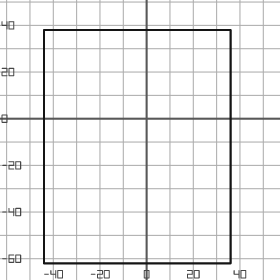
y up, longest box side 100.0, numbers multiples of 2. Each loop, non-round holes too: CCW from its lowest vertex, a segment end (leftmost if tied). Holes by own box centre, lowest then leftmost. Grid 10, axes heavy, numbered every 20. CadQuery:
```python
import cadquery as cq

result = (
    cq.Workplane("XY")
    .moveTo(-44.0, -62.0)
    .lineTo(36.0, -62.0)
    .lineTo(36.0, 38.0)
    .lineTo(-44.0, 38.0)
    .close()
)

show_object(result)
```